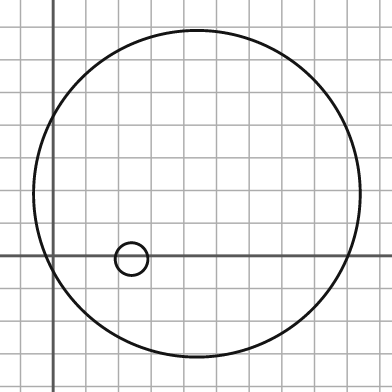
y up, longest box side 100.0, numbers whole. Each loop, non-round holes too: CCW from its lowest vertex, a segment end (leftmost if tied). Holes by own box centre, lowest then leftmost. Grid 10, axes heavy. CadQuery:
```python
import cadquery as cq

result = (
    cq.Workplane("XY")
    .moveTo(44.0, 19.0)
    .circle(50.0)
    .moveTo(24.0, -1.0)
    .circle(5.0)
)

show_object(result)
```